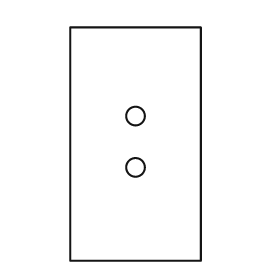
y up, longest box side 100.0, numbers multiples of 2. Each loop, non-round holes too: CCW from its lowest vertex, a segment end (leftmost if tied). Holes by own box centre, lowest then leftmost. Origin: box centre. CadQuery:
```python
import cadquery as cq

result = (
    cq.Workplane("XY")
    .moveTo(-28.0, -50.0)
    .lineTo(28.0, -50.0)
    .lineTo(28.0, 50.0)
    .lineTo(-28.0, 50.0)
    .close()
    .moveTo(0.0, -10.0)
    .circle(4.0)
    .moveTo(0.0, 12.0)
    .circle(4.0)
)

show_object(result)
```